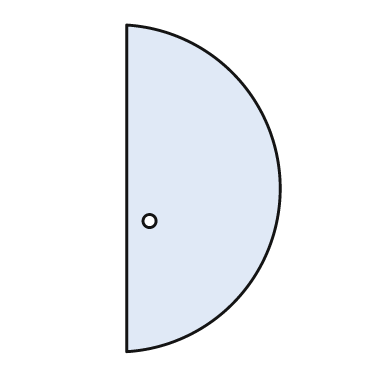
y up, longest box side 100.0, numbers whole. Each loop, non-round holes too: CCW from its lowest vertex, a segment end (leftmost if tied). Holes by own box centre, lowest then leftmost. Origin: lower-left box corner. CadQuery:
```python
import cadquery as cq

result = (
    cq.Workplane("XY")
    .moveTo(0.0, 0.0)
    .threePointArc((47.0, 50.0), (0.0, 100.0))
    .close()
    .moveTo(7.0, 40.0)
    .circle(2.0)
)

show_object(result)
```